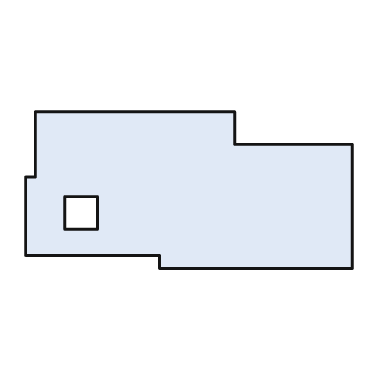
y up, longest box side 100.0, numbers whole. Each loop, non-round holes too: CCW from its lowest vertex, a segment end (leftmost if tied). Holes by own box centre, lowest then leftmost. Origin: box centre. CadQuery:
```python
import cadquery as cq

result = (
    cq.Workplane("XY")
    .moveTo(-9.0, -24.0)
    .lineTo(50.0, -24.0)
    .lineTo(50.0, 14.0)
    .lineTo(14.0, 14.0)
    .lineTo(14.0, 24.0)
    .lineTo(-47.0, 24.0)
    .lineTo(-47.0, 4.0)
    .lineTo(-50.0, 4.0)
    .lineTo(-50.0, -20.0)
    .lineTo(-9.0, -20.0)
    .close()
    .moveTo(-38.0, -12.0)
    .lineTo(-28.0, -12.0)
    .lineTo(-28.0, -2.0)
    .lineTo(-38.0, -2.0)
    .close()
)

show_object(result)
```